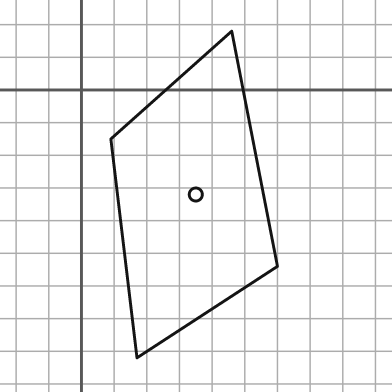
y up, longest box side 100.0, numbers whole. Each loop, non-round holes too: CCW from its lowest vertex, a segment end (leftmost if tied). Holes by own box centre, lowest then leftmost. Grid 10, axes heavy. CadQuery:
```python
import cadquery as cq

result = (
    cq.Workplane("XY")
    .moveTo(17.0, -82.0)
    .lineTo(60.0, -54.0)
    .lineTo(46.0, 18.0)
    .lineTo(9.0, -15.0)
    .close()
    .moveTo(35.0, -32.0)
    .circle(2.0)
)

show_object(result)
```